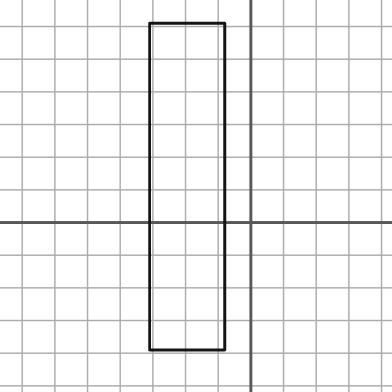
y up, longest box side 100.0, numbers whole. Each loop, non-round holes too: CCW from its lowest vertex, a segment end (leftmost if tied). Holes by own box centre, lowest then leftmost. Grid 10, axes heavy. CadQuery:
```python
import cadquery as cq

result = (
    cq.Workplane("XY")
    .moveTo(-31.0, -39.0)
    .lineTo(-8.0, -39.0)
    .lineTo(-8.0, 61.0)
    .lineTo(-31.0, 61.0)
    .close()
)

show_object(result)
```